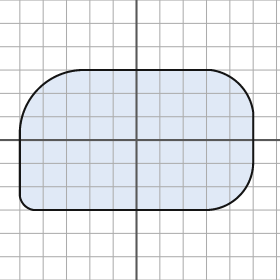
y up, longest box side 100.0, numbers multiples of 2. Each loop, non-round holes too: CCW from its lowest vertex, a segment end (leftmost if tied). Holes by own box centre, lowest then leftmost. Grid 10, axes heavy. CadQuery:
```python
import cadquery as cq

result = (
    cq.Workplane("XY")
    .moveTo(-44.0, -30.0)
    .lineTo(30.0, -30.0)
    .threePointArc((44.0, -24.0), (50.0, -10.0))
    .lineTo(50.0, 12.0)
    .threePointArc((44.0, 24.0), (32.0, 30.0))
    .lineTo(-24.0, 30.0)
    .threePointArc((-42.0, 22.0), (-50.0, 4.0))
    .lineTo(-50.0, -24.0)
    .threePointArc((-48.0, -28.0), (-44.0, -30.0))
    .close()
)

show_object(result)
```